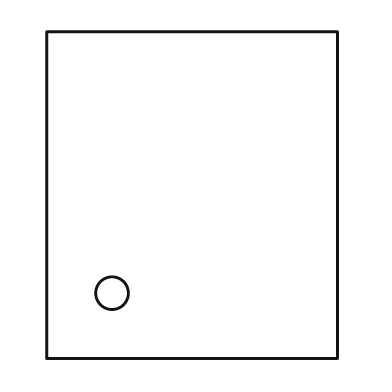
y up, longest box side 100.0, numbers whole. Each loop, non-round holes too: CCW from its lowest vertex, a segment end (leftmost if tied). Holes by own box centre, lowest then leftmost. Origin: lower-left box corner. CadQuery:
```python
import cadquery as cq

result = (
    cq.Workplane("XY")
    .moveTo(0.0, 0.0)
    .lineTo(89.0, 0.0)
    .lineTo(89.0, 100.0)
    .lineTo(0.0, 100.0)
    .close()
    .moveTo(20.0, 20.0)
    .circle(5.0)
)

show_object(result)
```